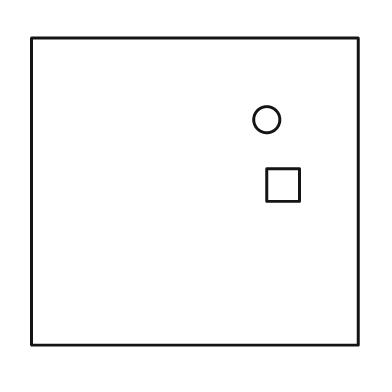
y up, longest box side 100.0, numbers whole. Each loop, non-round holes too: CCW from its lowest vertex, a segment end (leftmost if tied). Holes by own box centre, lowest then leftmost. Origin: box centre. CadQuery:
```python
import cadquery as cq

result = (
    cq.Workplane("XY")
    .moveTo(-50.0, -47.0)
    .lineTo(50.0, -47.0)
    .lineTo(50.0, 47.0)
    .lineTo(-50.0, 47.0)
    .close()
    .moveTo(22.0, -3.0)
    .lineTo(32.0, -3.0)
    .lineTo(32.0, 7.0)
    .lineTo(22.0, 7.0)
    .close()
    .moveTo(22.0, 22.0)
    .circle(4.0)
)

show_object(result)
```